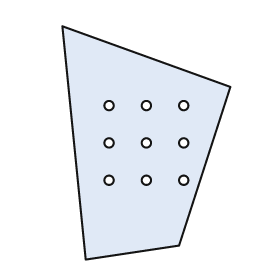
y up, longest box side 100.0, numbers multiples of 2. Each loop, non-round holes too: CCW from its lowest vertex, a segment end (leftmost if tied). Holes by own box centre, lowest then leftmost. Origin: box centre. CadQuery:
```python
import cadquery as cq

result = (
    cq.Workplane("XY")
    .moveTo(-26.0, -50.0)
    .lineTo(14.0, -44.0)
    .lineTo(36.0, 24.0)
    .lineTo(-36.0, 50.0)
    .close()
    .moveTo(-16.0, -16.0)
    .circle(2.0)
    .moveTo(0.0, -16.0)
    .circle(2.0)
    .moveTo(16.0, -16.0)
    .circle(2.0)
    .moveTo(-16.0, 0.0)
    .circle(2.0)
    .moveTo(0.0, 0.0)
    .circle(2.0)
    .moveTo(16.0, 0.0)
    .circle(2.0)
    .moveTo(-16.0, 16.0)
    .circle(2.0)
    .moveTo(0.0, 16.0)
    .circle(2.0)
    .moveTo(16.0, 16.0)
    .circle(2.0)
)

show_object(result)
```